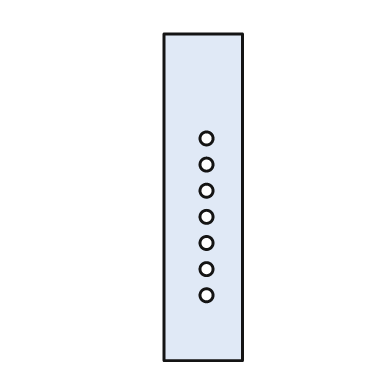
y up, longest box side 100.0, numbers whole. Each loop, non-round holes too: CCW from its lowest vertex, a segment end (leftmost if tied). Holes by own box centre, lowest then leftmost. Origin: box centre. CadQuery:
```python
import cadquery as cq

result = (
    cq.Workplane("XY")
    .moveTo(-12.0, -50.0)
    .lineTo(12.0, -50.0)
    .lineTo(12.0, 50.0)
    .lineTo(-12.0, 50.0)
    .close()
    .moveTo(1.0, -30.0)
    .circle(2.0)
    .moveTo(1.0, -22.0)
    .circle(2.0)
    .moveTo(1.0, -14.0)
    .circle(2.0)
    .moveTo(1.0, -6.0)
    .circle(2.0)
    .moveTo(1.0, 2.0)
    .circle(2.0)
    .moveTo(1.0, 10.0)
    .circle(2.0)
    .moveTo(1.0, 18.0)
    .circle(2.0)
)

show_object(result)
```